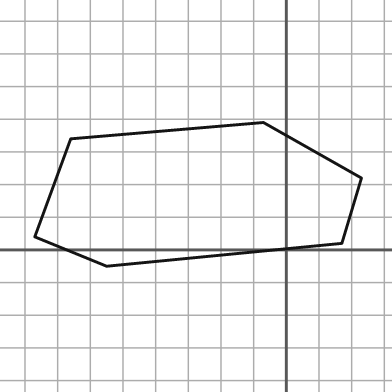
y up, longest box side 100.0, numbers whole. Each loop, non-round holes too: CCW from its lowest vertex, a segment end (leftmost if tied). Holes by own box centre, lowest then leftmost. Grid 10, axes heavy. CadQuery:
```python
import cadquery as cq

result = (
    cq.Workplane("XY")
    .moveTo(-55.0, -5.0)
    .lineTo(17.0, 2.0)
    .lineTo(23.0, 22.0)
    .lineTo(-7.0, 39.0)
    .lineTo(-66.0, 34.0)
    .lineTo(-77.0, 4.0)
    .close()
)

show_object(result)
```